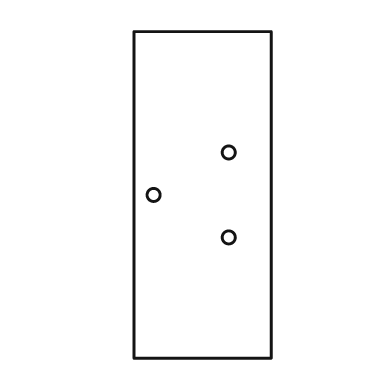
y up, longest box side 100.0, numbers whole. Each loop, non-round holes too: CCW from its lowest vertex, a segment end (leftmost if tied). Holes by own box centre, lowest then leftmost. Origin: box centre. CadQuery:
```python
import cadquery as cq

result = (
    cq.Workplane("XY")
    .moveTo(-21.0, -50.0)
    .lineTo(21.0, -50.0)
    .lineTo(21.0, 50.0)
    .lineTo(-21.0, 50.0)
    .close()
    .moveTo(8.0, -13.0)
    .circle(2.0)
    .moveTo(-15.0, 0.0)
    .circle(2.0)
    .moveTo(8.0, 13.0)
    .circle(2.0)
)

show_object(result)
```